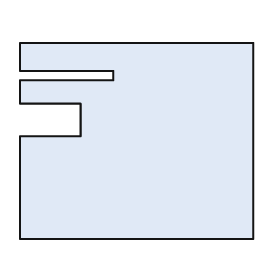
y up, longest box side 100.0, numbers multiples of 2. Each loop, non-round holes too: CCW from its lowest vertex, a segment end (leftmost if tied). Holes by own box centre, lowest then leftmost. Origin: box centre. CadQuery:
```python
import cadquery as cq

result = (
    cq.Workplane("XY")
    .moveTo(-50.0, -42.0)
    .lineTo(50.0, -42.0)
    .lineTo(50.0, 42.0)
    .lineTo(-50.0, 42.0)
    .lineTo(-50.0, 30.0)
    .lineTo(-10.0, 30.0)
    .lineTo(-10.0, 26.0)
    .lineTo(-50.0, 26.0)
    .lineTo(-50.0, 16.0)
    .lineTo(-24.0, 16.0)
    .lineTo(-24.0, 2.0)
    .lineTo(-50.0, 2.0)
    .close()
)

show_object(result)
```